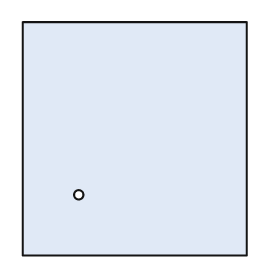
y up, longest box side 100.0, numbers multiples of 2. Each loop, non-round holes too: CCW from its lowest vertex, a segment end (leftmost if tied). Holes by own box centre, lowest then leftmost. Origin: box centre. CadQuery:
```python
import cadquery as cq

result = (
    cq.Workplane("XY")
    .moveTo(-48.0, -50.0)
    .lineTo(48.0, -50.0)
    .lineTo(48.0, 50.0)
    .lineTo(-48.0, 50.0)
    .close()
    .moveTo(-24.0, -24.0)
    .circle(2.0)
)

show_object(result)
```